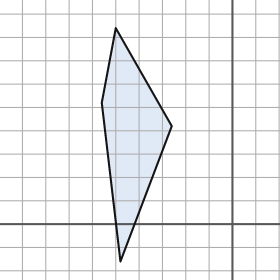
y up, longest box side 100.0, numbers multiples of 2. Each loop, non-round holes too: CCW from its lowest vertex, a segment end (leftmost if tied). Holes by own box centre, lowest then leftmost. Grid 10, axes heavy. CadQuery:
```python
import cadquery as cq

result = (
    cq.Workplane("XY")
    .moveTo(-48.0, -16.0)
    .lineTo(-26.0, 42.0)
    .lineTo(-50.0, 84.0)
    .lineTo(-56.0, 52.0)
    .close()
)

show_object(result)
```